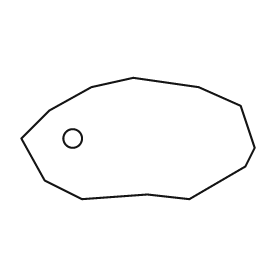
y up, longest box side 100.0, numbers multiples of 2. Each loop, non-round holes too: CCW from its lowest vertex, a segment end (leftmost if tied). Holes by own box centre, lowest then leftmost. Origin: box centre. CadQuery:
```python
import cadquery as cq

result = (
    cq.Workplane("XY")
    .moveTo(-24.0, -26.0)
    .lineTo(4.0, -24.0)
    .lineTo(22.0, -26.0)
    .lineTo(46.0, -12.0)
    .lineTo(50.0, -4.0)
    .lineTo(44.0, 14.0)
    .lineTo(26.0, 22.0)
    .lineTo(-2.0, 26.0)
    .lineTo(-20.0, 22.0)
    .lineTo(-38.0, 12.0)
    .lineTo(-50.0, 0.0)
    .lineTo(-40.0, -18.0)
    .close()
    .moveTo(-28.0, 0.0)
    .circle(4.0)
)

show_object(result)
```